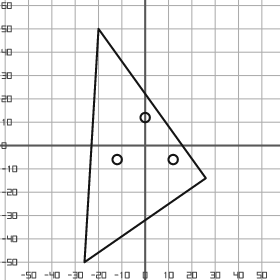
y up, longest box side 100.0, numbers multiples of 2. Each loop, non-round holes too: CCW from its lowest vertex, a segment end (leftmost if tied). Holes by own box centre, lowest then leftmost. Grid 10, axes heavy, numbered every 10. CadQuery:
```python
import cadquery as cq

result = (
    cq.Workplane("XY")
    .moveTo(-26.0, -50.0)
    .lineTo(26.0, -14.0)
    .lineTo(-20.0, 50.0)
    .close()
    .moveTo(-12.0, -6.0)
    .circle(2.0)
    .moveTo(12.0, -6.0)
    .circle(2.0)
    .moveTo(0.0, 12.0)
    .circle(2.0)
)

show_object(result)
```